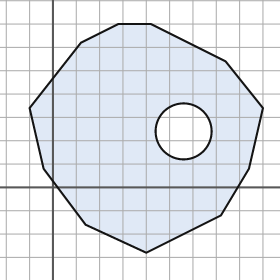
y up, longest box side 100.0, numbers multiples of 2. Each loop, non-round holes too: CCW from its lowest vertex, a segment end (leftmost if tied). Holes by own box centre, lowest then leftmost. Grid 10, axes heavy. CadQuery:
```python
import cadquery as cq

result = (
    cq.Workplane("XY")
    .moveTo(40.0, -28.0)
    .lineTo(72.0, -12.0)
    .lineTo(84.0, 8.0)
    .lineTo(90.0, 34.0)
    .lineTo(74.0, 54.0)
    .lineTo(42.0, 70.0)
    .lineTo(28.0, 70.0)
    .lineTo(12.0, 62.0)
    .lineTo(-10.0, 34.0)
    .lineTo(-4.0, 8.0)
    .lineTo(14.0, -16.0)
    .close()
    .moveTo(56.0, 24.0)
    .circle(12.0)
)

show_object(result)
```